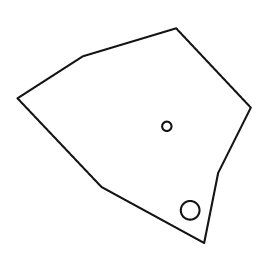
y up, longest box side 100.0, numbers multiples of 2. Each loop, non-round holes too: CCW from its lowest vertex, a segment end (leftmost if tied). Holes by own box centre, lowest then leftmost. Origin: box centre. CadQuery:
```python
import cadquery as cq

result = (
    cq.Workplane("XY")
    .moveTo(30.0, -46.0)
    .lineTo(36.0, -16.0)
    .lineTo(50.0, 12.0)
    .lineTo(18.0, 46.0)
    .lineTo(-22.0, 34.0)
    .lineTo(-50.0, 16.0)
    .lineTo(-14.0, -22.0)
    .close()
    .moveTo(24.0, -32.0)
    .circle(4.0)
    .moveTo(14.0, 4.0)
    .circle(2.0)
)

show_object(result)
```